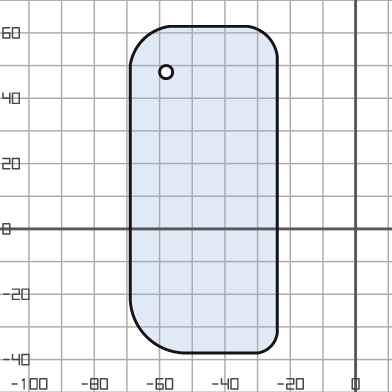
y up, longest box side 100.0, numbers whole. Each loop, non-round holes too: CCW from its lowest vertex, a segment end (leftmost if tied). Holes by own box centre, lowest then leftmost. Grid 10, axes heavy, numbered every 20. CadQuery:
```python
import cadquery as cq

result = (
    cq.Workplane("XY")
    .moveTo(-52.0, -38.0)
    .lineTo(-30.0, -38.0)
    .threePointArc((-26.0, -36.0), (-24.0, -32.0))
    .lineTo(-24.0, 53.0)
    .threePointArc((-27.0, 59.0), (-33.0, 62.0))
    .lineTo(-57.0, 62.0)
    .threePointArc((-65.0, 58.0), (-69.0, 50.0))
    .lineTo(-69.0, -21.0)
    .threePointArc((-64.0, -33.0), (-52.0, -38.0))
    .close()
    .moveTo(-58.0, 48.0)
    .circle(2.0)
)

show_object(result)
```